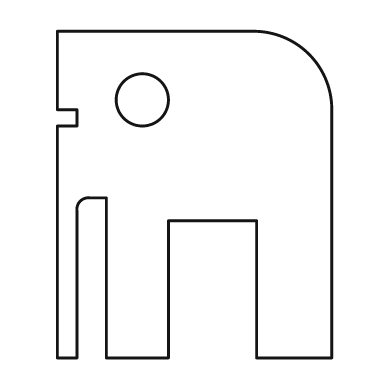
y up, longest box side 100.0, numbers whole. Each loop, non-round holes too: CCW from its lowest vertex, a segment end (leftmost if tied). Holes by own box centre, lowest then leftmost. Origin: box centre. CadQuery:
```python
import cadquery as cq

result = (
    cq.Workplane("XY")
    .moveTo(-42.0, -50.0)
    .lineTo(-36.0, -50.0)
    .lineTo(-36.0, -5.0)
    .threePointArc((-35.0, -2.0), (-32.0, -1.0))
    .lineTo(-27.0, -1.0)
    .lineTo(-27.0, -50.0)
    .lineTo(-8.0, -50.0)
    .lineTo(-8.0, -8.0)
    .lineTo(19.0, -8.0)
    .lineTo(19.0, -50.0)
    .lineTo(42.0, -50.0)
    .lineTo(42.0, 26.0)
    .threePointArc((35.0, 43.0), (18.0, 50.0))
    .lineTo(-42.0, 50.0)
    .lineTo(-42.0, 26.0)
    .lineTo(-36.0, 26.0)
    .lineTo(-36.0, 21.0)
    .lineTo(-42.0, 21.0)
    .close()
    .moveTo(-16.0, 29.0)
    .circle(8.0)
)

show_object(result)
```